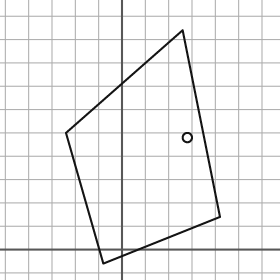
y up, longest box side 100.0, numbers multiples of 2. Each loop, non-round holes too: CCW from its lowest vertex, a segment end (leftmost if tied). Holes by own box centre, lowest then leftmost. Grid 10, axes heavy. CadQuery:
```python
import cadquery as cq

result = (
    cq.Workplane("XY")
    .moveTo(-8.0, -6.0)
    .lineTo(42.0, 14.0)
    .lineTo(26.0, 94.0)
    .lineTo(-24.0, 50.0)
    .close()
    .moveTo(28.0, 48.0)
    .circle(2.0)
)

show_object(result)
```